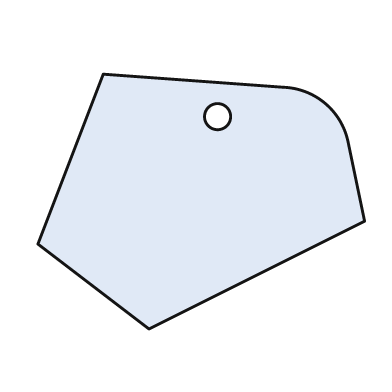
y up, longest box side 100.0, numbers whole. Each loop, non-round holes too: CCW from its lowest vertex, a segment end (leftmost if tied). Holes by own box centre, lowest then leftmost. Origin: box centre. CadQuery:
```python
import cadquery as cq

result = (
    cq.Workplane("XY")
    .moveTo(-16.0, -39.0)
    .lineTo(50.0, -6.0)
    .lineTo(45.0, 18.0)
    .threePointArc((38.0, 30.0), (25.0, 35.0))
    .lineTo(-30.0, 39.0)
    .lineTo(-50.0, -13.0)
    .close()
    .moveTo(5.0, 26.0)
    .circle(4.0)
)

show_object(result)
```